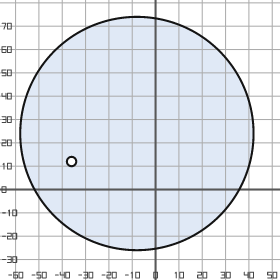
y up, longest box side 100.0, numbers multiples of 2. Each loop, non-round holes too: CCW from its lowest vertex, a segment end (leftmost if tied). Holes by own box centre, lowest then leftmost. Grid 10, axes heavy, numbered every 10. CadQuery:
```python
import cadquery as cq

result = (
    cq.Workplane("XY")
    .moveTo(-8.0, 24.0)
    .circle(50.0)
    .moveTo(-36.0, 12.0)
    .circle(2.0)
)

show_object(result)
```